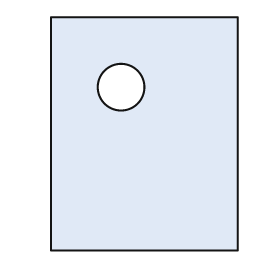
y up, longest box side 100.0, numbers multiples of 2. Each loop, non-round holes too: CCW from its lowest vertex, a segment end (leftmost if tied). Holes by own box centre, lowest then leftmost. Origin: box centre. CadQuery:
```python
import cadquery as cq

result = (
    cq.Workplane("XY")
    .moveTo(-40.0, -50.0)
    .lineTo(40.0, -50.0)
    .lineTo(40.0, 50.0)
    .lineTo(-40.0, 50.0)
    .close()
    .moveTo(-10.0, 20.0)
    .circle(10.0)
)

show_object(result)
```